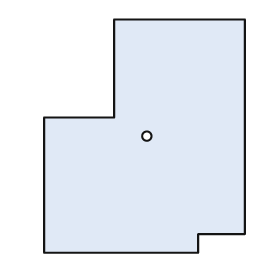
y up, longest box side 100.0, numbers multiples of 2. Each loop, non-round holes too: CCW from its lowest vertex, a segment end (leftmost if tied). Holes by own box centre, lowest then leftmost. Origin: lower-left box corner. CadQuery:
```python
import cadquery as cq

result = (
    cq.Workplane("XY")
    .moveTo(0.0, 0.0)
    .lineTo(66.0, 0.0)
    .lineTo(66.0, 8.0)
    .lineTo(86.0, 8.0)
    .lineTo(86.0, 100.0)
    .lineTo(30.0, 100.0)
    .lineTo(30.0, 58.0)
    .lineTo(0.0, 58.0)
    .close()
    .moveTo(44.0, 50.0)
    .circle(2.0)
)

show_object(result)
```